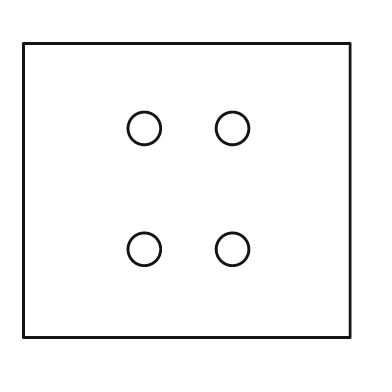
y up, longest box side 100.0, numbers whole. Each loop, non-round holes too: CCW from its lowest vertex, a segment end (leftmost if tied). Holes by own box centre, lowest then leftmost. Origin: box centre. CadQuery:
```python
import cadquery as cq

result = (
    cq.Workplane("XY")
    .moveTo(-50.0, -45.0)
    .lineTo(50.0, -45.0)
    .lineTo(50.0, 45.0)
    .lineTo(-50.0, 45.0)
    .close()
    .moveTo(-13.0, -18.0)
    .circle(5.0)
    .moveTo(14.0, -18.0)
    .circle(5.0)
    .moveTo(-13.0, 19.0)
    .circle(5.0)
    .moveTo(14.0, 19.0)
    .circle(5.0)
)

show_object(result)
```